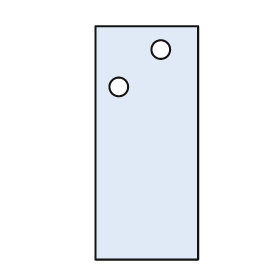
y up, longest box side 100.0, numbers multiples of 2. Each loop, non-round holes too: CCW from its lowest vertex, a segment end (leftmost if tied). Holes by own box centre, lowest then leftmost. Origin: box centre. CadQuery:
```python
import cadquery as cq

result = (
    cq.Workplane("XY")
    .moveTo(-22.0, -50.0)
    .lineTo(22.0, -50.0)
    .lineTo(22.0, 50.0)
    .lineTo(-22.0, 50.0)
    .close()
    .moveTo(-12.0, 24.0)
    .circle(4.0)
    .moveTo(6.0, 40.0)
    .circle(4.0)
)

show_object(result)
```